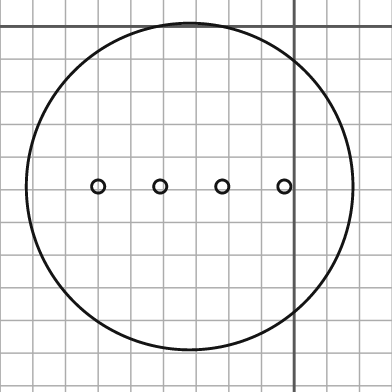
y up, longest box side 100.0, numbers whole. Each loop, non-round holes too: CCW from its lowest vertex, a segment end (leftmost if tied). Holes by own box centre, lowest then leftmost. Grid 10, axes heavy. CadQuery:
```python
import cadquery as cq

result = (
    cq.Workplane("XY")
    .moveTo(-32.0, -49.0)
    .circle(50.0)
    .moveTo(-60.0, -49.0)
    .circle(2.0)
    .moveTo(-41.0, -49.0)
    .circle(2.0)
    .moveTo(-22.0, -49.0)
    .circle(2.0)
    .moveTo(-3.0, -49.0)
    .circle(2.0)
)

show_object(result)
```